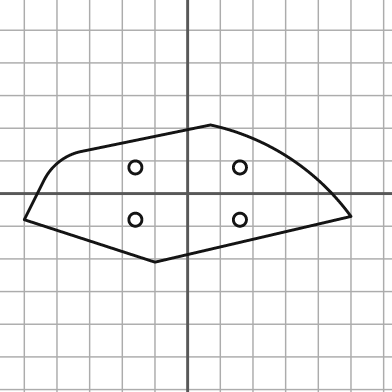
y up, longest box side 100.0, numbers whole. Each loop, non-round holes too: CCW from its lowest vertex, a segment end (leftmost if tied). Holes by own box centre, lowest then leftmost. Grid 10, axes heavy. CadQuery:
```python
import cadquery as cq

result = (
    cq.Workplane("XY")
    .moveTo(-10.0, -21.0)
    .lineTo(50.0, -7.0)
    .threePointArc((31.0, 11.0), (7.0, 21.0))
    .lineTo(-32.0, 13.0)
    .threePointArc((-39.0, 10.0), (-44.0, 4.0))
    .lineTo(-50.0, -8.0)
    .close()
    .moveTo(-16.0, -8.0)
    .circle(2.0)
    .moveTo(16.0, -8.0)
    .circle(2.0)
    .moveTo(-16.0, 8.0)
    .circle(2.0)
    .moveTo(16.0, 8.0)
    .circle(2.0)
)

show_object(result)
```